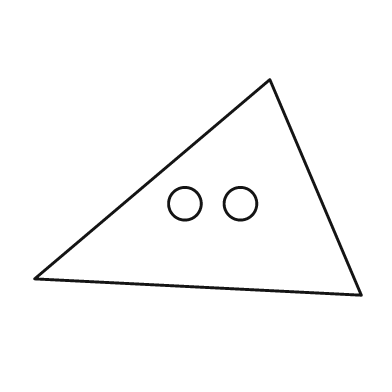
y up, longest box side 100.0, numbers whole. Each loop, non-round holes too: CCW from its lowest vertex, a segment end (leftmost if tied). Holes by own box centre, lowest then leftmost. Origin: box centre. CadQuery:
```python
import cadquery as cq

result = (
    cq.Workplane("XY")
    .moveTo(50.0, -33.0)
    .lineTo(22.0, 33.0)
    .lineTo(-50.0, -28.0)
    .close()
    .moveTo(-4.0, -5.0)
    .circle(5.0)
    .moveTo(13.0, -5.0)
    .circle(5.0)
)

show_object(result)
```